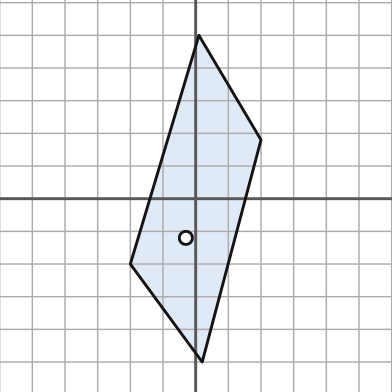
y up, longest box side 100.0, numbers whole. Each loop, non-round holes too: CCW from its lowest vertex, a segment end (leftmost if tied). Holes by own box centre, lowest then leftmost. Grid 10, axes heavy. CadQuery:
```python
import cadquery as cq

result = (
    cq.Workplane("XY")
    .moveTo(2.0, -50.0)
    .lineTo(20.0, 18.0)
    .lineTo(1.0, 50.0)
    .lineTo(-20.0, -20.0)
    .close()
    .moveTo(-3.0, -12.0)
    .circle(2.0)
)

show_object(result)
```